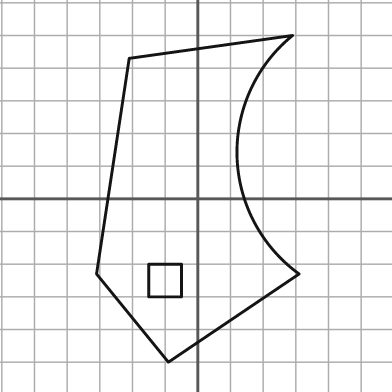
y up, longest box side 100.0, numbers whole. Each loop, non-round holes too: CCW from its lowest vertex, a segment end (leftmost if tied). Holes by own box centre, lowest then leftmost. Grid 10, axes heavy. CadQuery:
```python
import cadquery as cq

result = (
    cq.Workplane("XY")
    .moveTo(-9.0, -50.0)
    .lineTo(31.0, -23.0)
    .threePointArc((12.0, 13.0), (29.0, 50.0))
    .lineTo(-21.0, 43.0)
    .lineTo(-31.0, -23.0)
    .close()
    .moveTo(-15.0, -30.0)
    .lineTo(-5.0, -30.0)
    .lineTo(-5.0, -20.0)
    .lineTo(-15.0, -20.0)
    .close()
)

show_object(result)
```